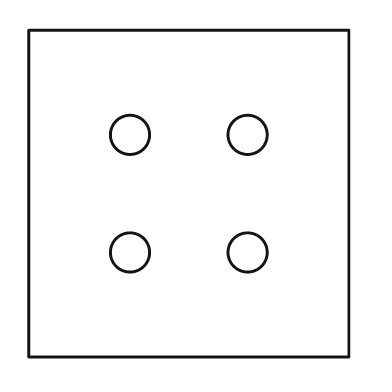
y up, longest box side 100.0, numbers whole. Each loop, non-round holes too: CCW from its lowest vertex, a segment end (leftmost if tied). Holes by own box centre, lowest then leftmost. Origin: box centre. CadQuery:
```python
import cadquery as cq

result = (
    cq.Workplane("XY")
    .moveTo(-49.0, -50.0)
    .lineTo(49.0, -50.0)
    .lineTo(49.0, 50.0)
    .lineTo(-49.0, 50.0)
    .close()
    .moveTo(-18.0, -18.0)
    .circle(6.0)
    .moveTo(18.0, -18.0)
    .circle(6.0)
    .moveTo(-18.0, 18.0)
    .circle(6.0)
    .moveTo(18.0, 18.0)
    .circle(6.0)
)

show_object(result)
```